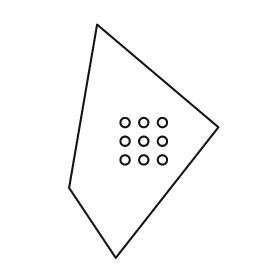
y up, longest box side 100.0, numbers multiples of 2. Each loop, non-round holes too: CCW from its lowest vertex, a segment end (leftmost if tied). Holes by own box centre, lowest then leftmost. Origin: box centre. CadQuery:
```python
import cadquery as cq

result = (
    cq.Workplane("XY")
    .moveTo(-12.0, -50.0)
    .lineTo(32.0, 6.0)
    .lineTo(-20.0, 50.0)
    .lineTo(-32.0, -20.0)
    .close()
    .moveTo(-8.0, -8.0)
    .circle(2.0)
    .moveTo(0.0, -8.0)
    .circle(2.0)
    .moveTo(8.0, -8.0)
    .circle(2.0)
    .moveTo(-8.0, 0.0)
    .circle(2.0)
    .moveTo(0.0, 0.0)
    .circle(2.0)
    .moveTo(8.0, 0.0)
    .circle(2.0)
    .moveTo(-8.0, 8.0)
    .circle(2.0)
    .moveTo(0.0, 8.0)
    .circle(2.0)
    .moveTo(8.0, 8.0)
    .circle(2.0)
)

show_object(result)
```